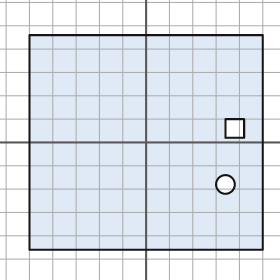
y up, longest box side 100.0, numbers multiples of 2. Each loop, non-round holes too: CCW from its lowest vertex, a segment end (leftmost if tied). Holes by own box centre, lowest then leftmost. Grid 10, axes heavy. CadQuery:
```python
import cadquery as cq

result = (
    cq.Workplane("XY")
    .moveTo(-50.0, -46.0)
    .lineTo(50.0, -46.0)
    .lineTo(50.0, 46.0)
    .lineTo(-50.0, 46.0)
    .close()
    .moveTo(34.0, -18.0)
    .circle(4.0)
    .moveTo(34.0, 2.0)
    .lineTo(42.0, 2.0)
    .lineTo(42.0, 10.0)
    .lineTo(34.0, 10.0)
    .close()
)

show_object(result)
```